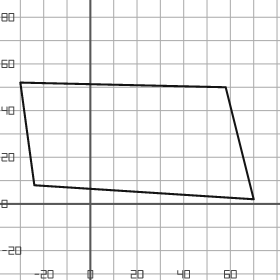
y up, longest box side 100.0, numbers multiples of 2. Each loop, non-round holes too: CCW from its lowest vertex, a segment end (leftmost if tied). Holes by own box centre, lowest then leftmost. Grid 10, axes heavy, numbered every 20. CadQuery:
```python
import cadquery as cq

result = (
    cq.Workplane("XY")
    .moveTo(70.0, 2.0)
    .lineTo(58.0, 50.0)
    .lineTo(-30.0, 52.0)
    .lineTo(-24.0, 8.0)
    .close()
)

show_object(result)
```